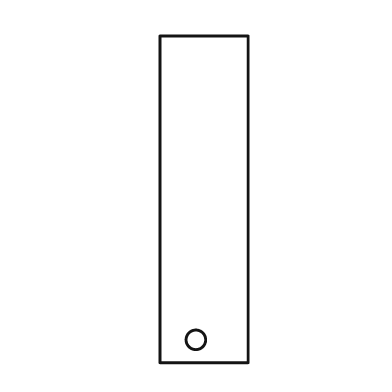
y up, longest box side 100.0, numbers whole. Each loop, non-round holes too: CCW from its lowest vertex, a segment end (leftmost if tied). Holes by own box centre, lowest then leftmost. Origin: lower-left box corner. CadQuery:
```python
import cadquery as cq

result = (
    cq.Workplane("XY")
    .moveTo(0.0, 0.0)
    .lineTo(27.0, 0.0)
    .lineTo(27.0, 100.0)
    .lineTo(0.0, 100.0)
    .close()
    .moveTo(11.0, 7.0)
    .circle(3.0)
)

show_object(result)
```